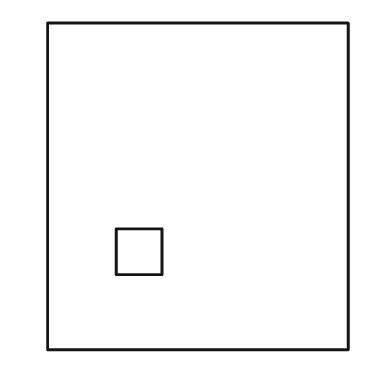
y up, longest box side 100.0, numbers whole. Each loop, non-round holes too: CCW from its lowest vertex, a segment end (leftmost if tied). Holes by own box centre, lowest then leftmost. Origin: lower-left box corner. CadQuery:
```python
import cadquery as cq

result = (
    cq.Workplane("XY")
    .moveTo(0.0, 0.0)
    .lineTo(92.0, 0.0)
    .lineTo(92.0, 100.0)
    .lineTo(0.0, 100.0)
    .close()
    .moveTo(21.0, 23.0)
    .lineTo(35.0, 23.0)
    .lineTo(35.0, 37.0)
    .lineTo(21.0, 37.0)
    .close()
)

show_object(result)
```